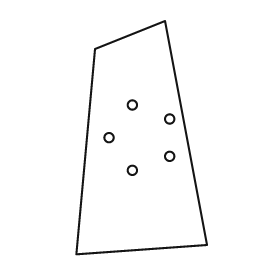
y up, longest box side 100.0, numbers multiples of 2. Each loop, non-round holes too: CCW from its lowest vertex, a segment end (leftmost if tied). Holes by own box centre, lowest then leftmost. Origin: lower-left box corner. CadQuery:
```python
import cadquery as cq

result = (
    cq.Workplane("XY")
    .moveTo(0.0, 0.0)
    .lineTo(56.0, 4.0)
    .lineTo(38.0, 100.0)
    .lineTo(8.0, 88.0)
    .close()
    .moveTo(24.0, 36.0)
    .circle(2.0)
    .moveTo(40.0, 42.0)
    .circle(2.0)
    .moveTo(14.0, 50.0)
    .circle(2.0)
    .moveTo(40.0, 58.0)
    .circle(2.0)
    .moveTo(24.0, 64.0)
    .circle(2.0)
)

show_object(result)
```